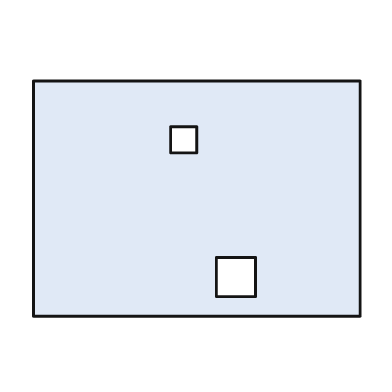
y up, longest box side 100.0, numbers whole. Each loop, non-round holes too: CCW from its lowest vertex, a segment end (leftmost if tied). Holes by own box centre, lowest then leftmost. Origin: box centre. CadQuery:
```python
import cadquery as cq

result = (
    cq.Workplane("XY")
    .moveTo(-50.0, -36.0)
    .lineTo(50.0, -36.0)
    .lineTo(50.0, 36.0)
    .lineTo(-50.0, 36.0)
    .close()
    .moveTo(6.0, -30.0)
    .lineTo(18.0, -30.0)
    .lineTo(18.0, -18.0)
    .lineTo(6.0, -18.0)
    .close()
    .moveTo(-8.0, 14.0)
    .lineTo(0.0, 14.0)
    .lineTo(0.0, 22.0)
    .lineTo(-8.0, 22.0)
    .close()
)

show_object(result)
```